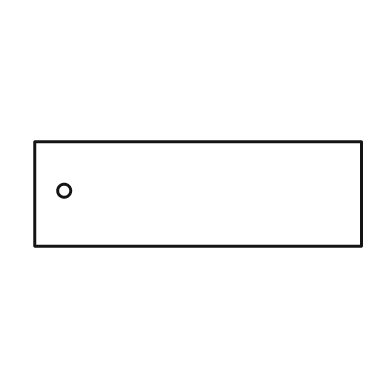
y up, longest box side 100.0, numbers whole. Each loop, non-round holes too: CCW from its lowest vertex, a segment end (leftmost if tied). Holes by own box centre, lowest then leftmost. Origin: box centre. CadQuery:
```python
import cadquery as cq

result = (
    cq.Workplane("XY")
    .moveTo(-50.0, -16.0)
    .lineTo(50.0, -16.0)
    .lineTo(50.0, 16.0)
    .lineTo(-50.0, 16.0)
    .close()
    .moveTo(-41.0, 1.0)
    .circle(2.0)
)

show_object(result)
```